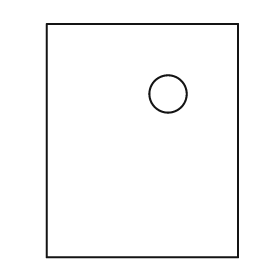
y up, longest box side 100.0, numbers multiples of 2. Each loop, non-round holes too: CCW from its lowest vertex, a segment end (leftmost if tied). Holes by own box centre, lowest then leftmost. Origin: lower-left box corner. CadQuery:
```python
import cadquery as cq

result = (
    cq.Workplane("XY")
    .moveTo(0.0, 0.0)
    .lineTo(82.0, 0.0)
    .lineTo(82.0, 100.0)
    .lineTo(0.0, 100.0)
    .close()
    .moveTo(52.0, 70.0)
    .circle(8.0)
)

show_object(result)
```